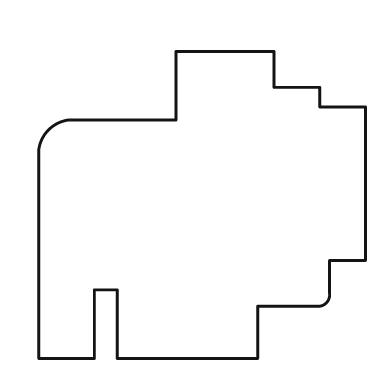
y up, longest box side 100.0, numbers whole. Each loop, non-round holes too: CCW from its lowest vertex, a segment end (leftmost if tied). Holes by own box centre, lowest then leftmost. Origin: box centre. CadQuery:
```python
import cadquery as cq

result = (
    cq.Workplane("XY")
    .moveTo(-50.0, -47.0)
    .lineTo(-33.0, -47.0)
    .lineTo(-33.0, -26.0)
    .lineTo(-26.0, -26.0)
    .lineTo(-26.0, -47.0)
    .lineTo(17.0, -47.0)
    .lineTo(17.0, -31.0)
    .lineTo(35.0, -31.0)
    .threePointArc((38.0, -30.0), (39.0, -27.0))
    .lineTo(39.0, -17.0)
    .lineTo(50.0, -17.0)
    .lineTo(50.0, 30.0)
    .lineTo(36.0, 30.0)
    .lineTo(36.0, 36.0)
    .lineTo(22.0, 36.0)
    .lineTo(22.0, 47.0)
    .lineTo(-8.0, 47.0)
    .lineTo(-8.0, 26.0)
    .lineTo(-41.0, 26.0)
    .threePointArc((-47.0, 23.0), (-50.0, 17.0))
    .close()
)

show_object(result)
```